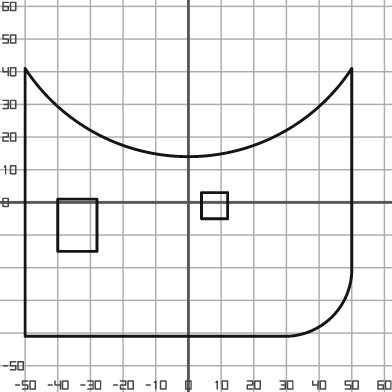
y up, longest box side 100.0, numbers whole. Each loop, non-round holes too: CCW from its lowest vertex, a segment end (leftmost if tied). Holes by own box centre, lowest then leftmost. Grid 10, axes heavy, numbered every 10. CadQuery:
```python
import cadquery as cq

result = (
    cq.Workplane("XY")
    .moveTo(-50.0, -41.0)
    .lineTo(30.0, -41.0)
    .threePointArc((44.0, -35.0), (50.0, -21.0))
    .lineTo(50.0, 41.0)
    .threePointArc((0.0, 14.0), (-50.0, 41.0))
    .close()
    .moveTo(-40.0, -15.0)
    .lineTo(-28.0, -15.0)
    .lineTo(-28.0, 1.0)
    .lineTo(-40.0, 1.0)
    .close()
    .moveTo(4.0, -5.0)
    .lineTo(12.0, -5.0)
    .lineTo(12.0, 3.0)
    .lineTo(4.0, 3.0)
    .close()
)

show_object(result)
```